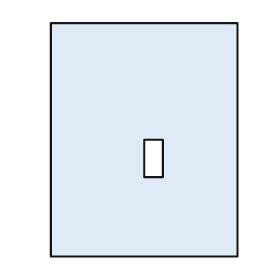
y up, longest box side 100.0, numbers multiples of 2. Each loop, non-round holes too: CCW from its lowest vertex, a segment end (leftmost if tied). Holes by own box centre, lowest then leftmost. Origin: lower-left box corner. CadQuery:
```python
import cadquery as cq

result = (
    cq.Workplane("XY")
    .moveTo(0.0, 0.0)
    .lineTo(80.0, 0.0)
    .lineTo(80.0, 100.0)
    .lineTo(0.0, 100.0)
    .close()
    .moveTo(40.0, 34.0)
    .lineTo(48.0, 34.0)
    .lineTo(48.0, 50.0)
    .lineTo(40.0, 50.0)
    .close()
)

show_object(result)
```